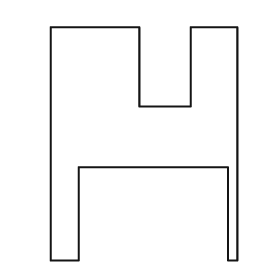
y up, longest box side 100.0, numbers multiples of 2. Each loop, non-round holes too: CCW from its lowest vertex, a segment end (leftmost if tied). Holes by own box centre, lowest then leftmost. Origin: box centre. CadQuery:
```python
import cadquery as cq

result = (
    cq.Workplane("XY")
    .moveTo(-40.0, -50.0)
    .lineTo(-28.0, -50.0)
    .lineTo(-28.0, -10.0)
    .lineTo(36.0, -10.0)
    .lineTo(36.0, -50.0)
    .lineTo(40.0, -50.0)
    .lineTo(40.0, 50.0)
    .lineTo(20.0, 50.0)
    .lineTo(20.0, 16.0)
    .lineTo(-2.0, 16.0)
    .lineTo(-2.0, 50.0)
    .lineTo(-40.0, 50.0)
    .close()
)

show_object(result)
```